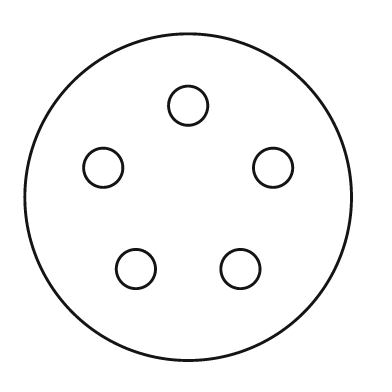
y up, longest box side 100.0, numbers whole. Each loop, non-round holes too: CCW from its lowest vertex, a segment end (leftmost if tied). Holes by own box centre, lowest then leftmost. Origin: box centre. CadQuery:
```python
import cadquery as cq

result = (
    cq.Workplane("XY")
    .moveTo(0.0, 0.0)
    .circle(50.0)
    .moveTo(-16.0, -22.0)
    .circle(6.0)
    .moveTo(16.0, -22.0)
    .circle(6.0)
    .moveTo(-26.0, 9.0)
    .circle(6.0)
    .moveTo(26.0, 9.0)
    .circle(6.0)
    .moveTo(0.0, 28.0)
    .circle(6.0)
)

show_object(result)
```